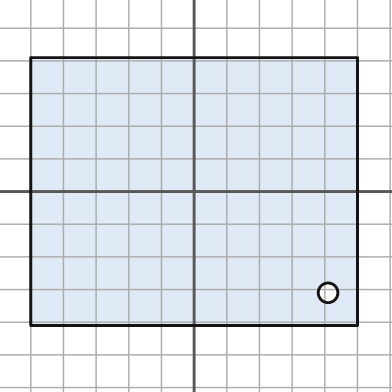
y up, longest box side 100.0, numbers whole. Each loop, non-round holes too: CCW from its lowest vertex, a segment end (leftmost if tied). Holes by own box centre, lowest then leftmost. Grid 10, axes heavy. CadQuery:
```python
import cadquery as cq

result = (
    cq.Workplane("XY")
    .moveTo(-50.0, -41.0)
    .lineTo(50.0, -41.0)
    .lineTo(50.0, 41.0)
    .lineTo(-50.0, 41.0)
    .close()
    .moveTo(41.0, -31.0)
    .circle(3.0)
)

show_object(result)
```